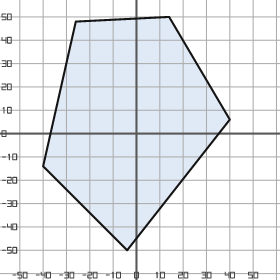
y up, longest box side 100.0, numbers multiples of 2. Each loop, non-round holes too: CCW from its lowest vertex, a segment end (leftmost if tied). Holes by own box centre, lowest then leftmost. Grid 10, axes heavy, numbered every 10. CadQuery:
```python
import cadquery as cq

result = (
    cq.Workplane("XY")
    .moveTo(-4.0, -50.0)
    .lineTo(40.0, 6.0)
    .lineTo(14.0, 50.0)
    .lineTo(-26.0, 48.0)
    .lineTo(-40.0, -14.0)
    .close()
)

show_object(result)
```